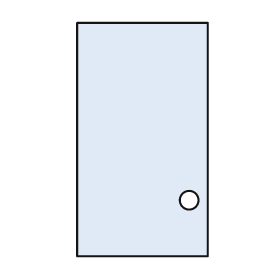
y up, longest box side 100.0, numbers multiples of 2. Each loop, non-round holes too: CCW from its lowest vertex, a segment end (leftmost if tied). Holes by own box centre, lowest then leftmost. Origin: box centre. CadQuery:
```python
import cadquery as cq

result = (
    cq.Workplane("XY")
    .moveTo(-28.0, -50.0)
    .lineTo(28.0, -50.0)
    .lineTo(28.0, 50.0)
    .lineTo(-28.0, 50.0)
    .close()
    .moveTo(20.0, -26.0)
    .circle(4.0)
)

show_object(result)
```